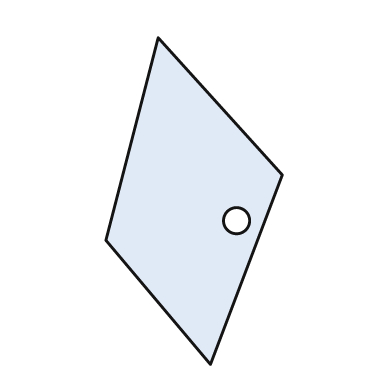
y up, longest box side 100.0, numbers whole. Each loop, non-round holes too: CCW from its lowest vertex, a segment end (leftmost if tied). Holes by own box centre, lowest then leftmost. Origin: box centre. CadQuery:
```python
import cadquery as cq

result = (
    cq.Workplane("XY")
    .moveTo(5.0, -50.0)
    .lineTo(27.0, 8.0)
    .lineTo(-11.0, 50.0)
    .lineTo(-27.0, -12.0)
    .close()
    .moveTo(13.0, -6.0)
    .circle(4.0)
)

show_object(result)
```